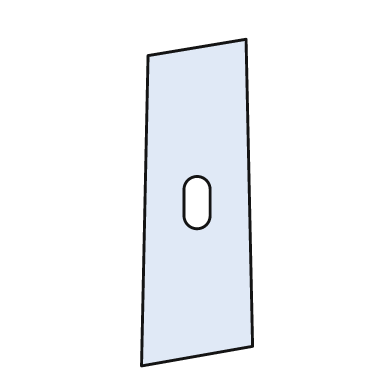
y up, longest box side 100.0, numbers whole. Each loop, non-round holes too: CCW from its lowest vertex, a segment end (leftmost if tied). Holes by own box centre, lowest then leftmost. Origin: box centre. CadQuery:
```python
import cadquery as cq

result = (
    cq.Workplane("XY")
    .moveTo(-17.0, -50.0)
    .lineTo(17.0, -44.0)
    .lineTo(15.0, 50.0)
    .lineTo(-15.0, 45.0)
    .close()
    .moveTo(-4.0, -4.0)
    .threePointArc((0.0, -8.0), (4.0, -4.0))
    .lineTo(4.0, 4.0)
    .threePointArc((0.0, 8.0), (-4.0, 4.0))
    .close()
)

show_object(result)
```